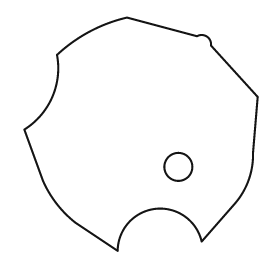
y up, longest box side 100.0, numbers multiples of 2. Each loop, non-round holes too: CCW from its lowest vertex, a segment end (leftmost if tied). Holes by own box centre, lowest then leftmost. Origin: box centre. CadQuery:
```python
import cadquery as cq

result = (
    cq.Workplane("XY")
    .moveTo(-10.0, -50.0)
    .threePointArc((6.0, -32.0), (26.0, -46.0))
    .lineTo(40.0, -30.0)
    .threePointArc((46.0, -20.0), (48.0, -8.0))
    .lineTo(50.0, 16.0)
    .lineTo(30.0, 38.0)
    .threePointArc((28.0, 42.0), (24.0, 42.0))
    .lineTo(-6.0, 50.0)
    .threePointArc((-22.0, 44.0), (-36.0, 34.0))
    .threePointArc((-38.0, 16.0), (-50.0, 2.0))
    .lineTo(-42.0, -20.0)
    .threePointArc((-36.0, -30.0), (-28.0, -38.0))
    .close()
    .moveTo(16.0, -14.0)
    .circle(6.0)
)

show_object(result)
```